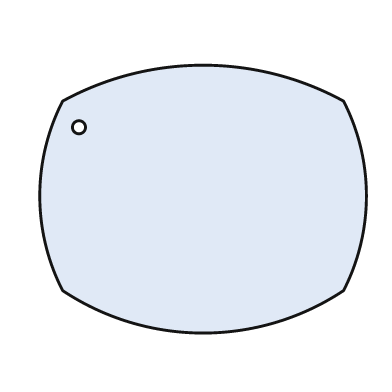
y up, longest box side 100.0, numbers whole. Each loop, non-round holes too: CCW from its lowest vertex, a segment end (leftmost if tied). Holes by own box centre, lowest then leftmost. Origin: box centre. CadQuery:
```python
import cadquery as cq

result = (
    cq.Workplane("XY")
    .moveTo(-43.0, -28.0)
    .threePointArc((0.0, -41.0), (43.0, -28.0))
    .threePointArc((50.0, 1.0), (43.0, 30.0))
    .threePointArc((0.0, 41.0), (-43.0, 30.0))
    .threePointArc((-50.0, 1.0), (-43.0, -28.0))
    .close()
    .moveTo(-38.0, 22.0)
    .circle(2.0)
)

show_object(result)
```